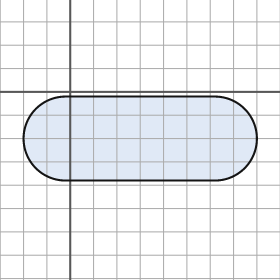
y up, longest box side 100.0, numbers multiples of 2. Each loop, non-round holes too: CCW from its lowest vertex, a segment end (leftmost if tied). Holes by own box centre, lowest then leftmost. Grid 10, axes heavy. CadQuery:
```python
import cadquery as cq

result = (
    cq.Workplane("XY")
    .moveTo(-2.0, -38.0)
    .lineTo(62.0, -38.0)
    .threePointArc((80.0, -20.0), (62.0, -2.0))
    .lineTo(-2.0, -2.0)
    .threePointArc((-20.0, -20.0), (-2.0, -38.0))
    .close()
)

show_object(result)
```